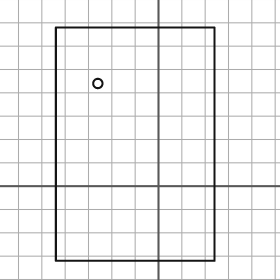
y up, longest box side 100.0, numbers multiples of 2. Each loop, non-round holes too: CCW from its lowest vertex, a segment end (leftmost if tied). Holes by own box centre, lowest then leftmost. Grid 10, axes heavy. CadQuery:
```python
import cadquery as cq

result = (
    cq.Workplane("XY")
    .moveTo(-44.0, -32.0)
    .lineTo(24.0, -32.0)
    .lineTo(24.0, 68.0)
    .lineTo(-44.0, 68.0)
    .close()
    .moveTo(-26.0, 44.0)
    .circle(2.0)
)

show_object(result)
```